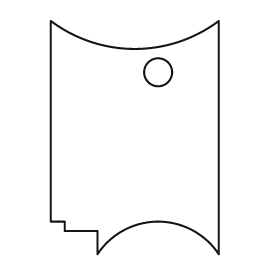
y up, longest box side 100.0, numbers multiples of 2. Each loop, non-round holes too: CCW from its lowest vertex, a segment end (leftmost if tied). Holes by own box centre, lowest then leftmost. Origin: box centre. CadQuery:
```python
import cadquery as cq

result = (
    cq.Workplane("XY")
    .moveTo(-16.0, -50.0)
    .threePointArc((10.0, -36.0), (36.0, -50.0))
    .lineTo(36.0, 50.0)
    .threePointArc((0.0, 38.0), (-36.0, 50.0))
    .lineTo(-36.0, -36.0)
    .lineTo(-30.0, -36.0)
    .lineTo(-30.0, -40.0)
    .lineTo(-16.0, -40.0)
    .close()
    .moveTo(10.0, 28.0)
    .circle(6.0)
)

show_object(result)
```